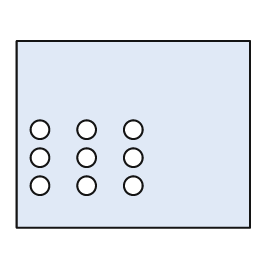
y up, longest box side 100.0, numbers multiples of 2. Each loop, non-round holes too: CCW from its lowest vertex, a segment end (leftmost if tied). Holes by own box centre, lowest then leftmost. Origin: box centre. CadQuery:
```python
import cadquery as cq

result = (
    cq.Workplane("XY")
    .moveTo(-50.0, -40.0)
    .lineTo(50.0, -40.0)
    .lineTo(50.0, 40.0)
    .lineTo(-50.0, 40.0)
    .close()
    .moveTo(-40.0, -22.0)
    .circle(4.0)
    .moveTo(-20.0, -22.0)
    .circle(4.0)
    .moveTo(0.0, -22.0)
    .circle(4.0)
    .moveTo(-40.0, -10.0)
    .circle(4.0)
    .moveTo(-20.0, -10.0)
    .circle(4.0)
    .moveTo(0.0, -10.0)
    .circle(4.0)
    .moveTo(-40.0, 2.0)
    .circle(4.0)
    .moveTo(-20.0, 2.0)
    .circle(4.0)
    .moveTo(0.0, 2.0)
    .circle(4.0)
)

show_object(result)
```